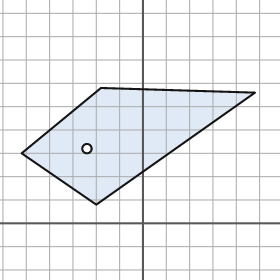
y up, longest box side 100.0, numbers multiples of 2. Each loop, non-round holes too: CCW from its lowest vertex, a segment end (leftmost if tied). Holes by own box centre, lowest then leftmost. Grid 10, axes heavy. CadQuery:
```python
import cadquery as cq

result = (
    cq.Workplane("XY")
    .moveTo(-20.0, 8.0)
    .lineTo(48.0, 56.0)
    .lineTo(-18.0, 58.0)
    .lineTo(-52.0, 30.0)
    .close()
    .moveTo(-24.0, 32.0)
    .circle(2.0)
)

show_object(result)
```